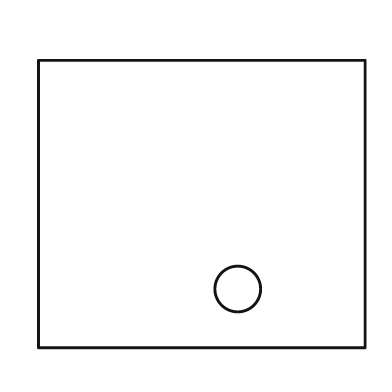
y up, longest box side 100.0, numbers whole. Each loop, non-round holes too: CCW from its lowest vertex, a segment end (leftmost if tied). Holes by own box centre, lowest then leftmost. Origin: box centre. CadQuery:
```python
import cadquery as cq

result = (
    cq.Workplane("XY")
    .moveTo(-50.0, -44.0)
    .lineTo(50.0, -44.0)
    .lineTo(50.0, 44.0)
    .lineTo(-50.0, 44.0)
    .close()
    .moveTo(11.0, -26.0)
    .circle(7.0)
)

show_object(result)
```